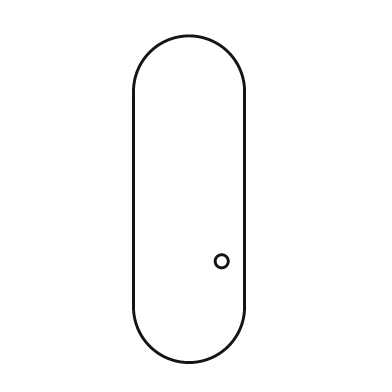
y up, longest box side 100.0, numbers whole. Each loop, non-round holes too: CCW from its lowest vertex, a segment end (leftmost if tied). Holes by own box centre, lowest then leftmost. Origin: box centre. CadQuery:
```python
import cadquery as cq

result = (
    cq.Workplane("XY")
    .moveTo(-17.0, -33.0)
    .threePointArc((0.0, -50.0), (17.0, -33.0))
    .lineTo(17.0, 33.0)
    .threePointArc((0.0, 50.0), (-17.0, 33.0))
    .close()
    .moveTo(10.0, -19.0)
    .circle(2.0)
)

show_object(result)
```